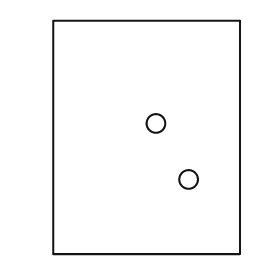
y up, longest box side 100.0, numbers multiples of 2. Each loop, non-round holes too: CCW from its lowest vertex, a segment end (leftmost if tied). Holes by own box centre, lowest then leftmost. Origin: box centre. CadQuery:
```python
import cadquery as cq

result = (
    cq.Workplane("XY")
    .moveTo(-40.0, -50.0)
    .lineTo(40.0, -50.0)
    .lineTo(40.0, 50.0)
    .lineTo(-40.0, 50.0)
    .close()
    .moveTo(18.0, -18.0)
    .circle(4.0)
    .moveTo(4.0, 6.0)
    .circle(4.0)
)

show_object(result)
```